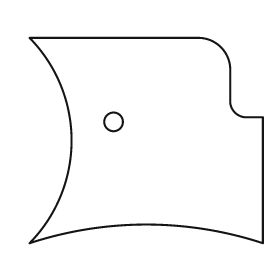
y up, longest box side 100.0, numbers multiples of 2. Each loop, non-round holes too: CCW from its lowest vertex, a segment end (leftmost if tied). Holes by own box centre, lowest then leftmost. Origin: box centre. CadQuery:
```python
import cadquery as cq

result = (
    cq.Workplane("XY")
    .moveTo(-50.0, -44.0)
    .threePointArc((0.0, -36.0), (50.0, -44.0))
    .lineTo(50.0, 10.0)
    .lineTo(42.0, 10.0)
    .threePointArc((38.0, 12.0), (36.0, 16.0))
    .lineTo(36.0, 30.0)
    .threePointArc((32.0, 40.0), (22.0, 44.0))
    .lineTo(-50.0, 44.0)
    .threePointArc((-32.0, 0.0), (-50.0, -44.0))
    .close()
    .moveTo(-14.0, 8.0)
    .circle(4.0)
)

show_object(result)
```